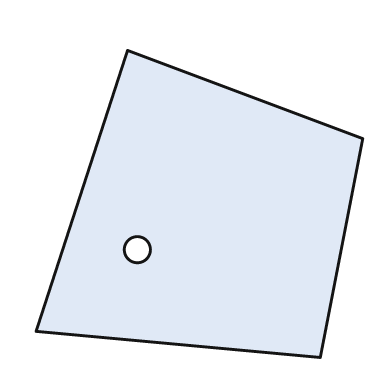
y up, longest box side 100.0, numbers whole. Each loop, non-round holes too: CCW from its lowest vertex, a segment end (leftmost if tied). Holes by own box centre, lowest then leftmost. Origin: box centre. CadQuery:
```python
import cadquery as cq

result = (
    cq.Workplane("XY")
    .moveTo(37.0, -47.0)
    .lineTo(50.0, 20.0)
    .lineTo(-22.0, 47.0)
    .lineTo(-50.0, -39.0)
    .close()
    .moveTo(-19.0, -14.0)
    .circle(4.0)
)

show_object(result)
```